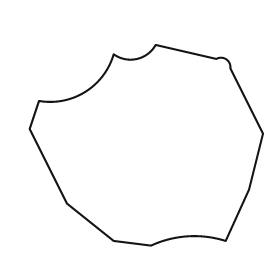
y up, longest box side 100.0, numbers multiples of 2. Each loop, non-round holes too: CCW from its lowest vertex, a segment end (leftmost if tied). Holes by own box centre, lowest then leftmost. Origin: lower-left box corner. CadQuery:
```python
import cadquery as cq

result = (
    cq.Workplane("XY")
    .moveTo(52.0, 0.0)
    .threePointArc((68.0, 4.0), (84.0, 2.0))
    .lineTo(94.0, 24.0)
    .lineTo(100.0, 48.0)
    .lineTo(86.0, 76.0)
    .threePointArc((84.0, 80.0), (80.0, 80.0))
    .lineTo(54.0, 86.0)
    .threePointArc((46.0, 80.0), (36.0, 82.0))
    .threePointArc((24.0, 66.0), (4.0, 62.0))
    .lineTo(0.0, 50.0)
    .lineTo(16.0, 18.0)
    .lineTo(36.0, 2.0)
    .close()
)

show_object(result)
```